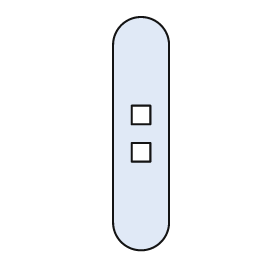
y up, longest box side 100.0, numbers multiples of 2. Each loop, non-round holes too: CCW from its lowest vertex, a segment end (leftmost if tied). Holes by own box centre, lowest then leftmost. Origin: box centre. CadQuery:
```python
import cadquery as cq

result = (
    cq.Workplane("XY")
    .moveTo(-12.0, -38.0)
    .threePointArc((0.0, -50.0), (12.0, -38.0))
    .lineTo(12.0, 38.0)
    .threePointArc((0.0, 50.0), (-12.0, 38.0))
    .close()
    .moveTo(-4.0, -12.0)
    .lineTo(4.0, -12.0)
    .lineTo(4.0, -4.0)
    .lineTo(-4.0, -4.0)
    .close()
    .moveTo(-4.0, 4.0)
    .lineTo(4.0, 4.0)
    .lineTo(4.0, 12.0)
    .lineTo(-4.0, 12.0)
    .close()
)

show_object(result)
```